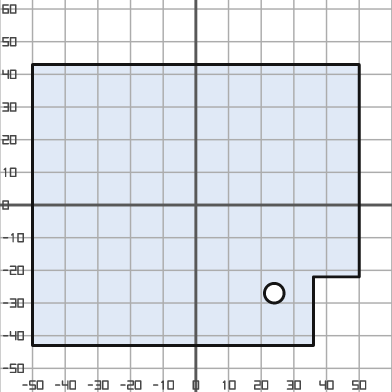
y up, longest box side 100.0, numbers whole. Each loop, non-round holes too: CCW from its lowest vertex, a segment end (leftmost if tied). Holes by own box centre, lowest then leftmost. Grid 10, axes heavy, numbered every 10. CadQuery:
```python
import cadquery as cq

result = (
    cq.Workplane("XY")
    .moveTo(-50.0, -43.0)
    .lineTo(36.0, -43.0)
    .lineTo(36.0, -22.0)
    .lineTo(50.0, -22.0)
    .lineTo(50.0, 43.0)
    .lineTo(-50.0, 43.0)
    .close()
    .moveTo(24.0, -27.0)
    .circle(3.0)
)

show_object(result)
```